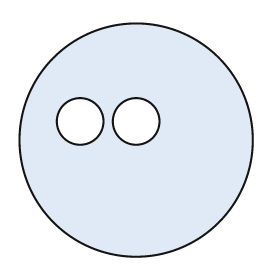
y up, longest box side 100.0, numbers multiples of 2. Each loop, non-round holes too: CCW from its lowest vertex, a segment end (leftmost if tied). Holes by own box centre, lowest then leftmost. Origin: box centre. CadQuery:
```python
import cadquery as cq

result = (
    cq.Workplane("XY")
    .moveTo(0.0, 0.0)
    .circle(50.0)
    .moveTo(-24.0, 8.0)
    .circle(10.0)
    .moveTo(0.0, 8.0)
    .circle(10.0)
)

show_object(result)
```